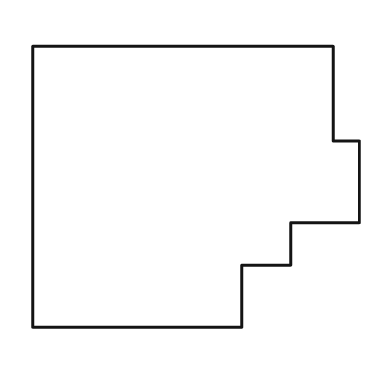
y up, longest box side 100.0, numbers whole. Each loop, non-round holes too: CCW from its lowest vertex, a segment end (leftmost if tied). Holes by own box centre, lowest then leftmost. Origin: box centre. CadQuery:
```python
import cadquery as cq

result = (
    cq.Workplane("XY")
    .moveTo(-50.0, -43.0)
    .lineTo(14.0, -43.0)
    .lineTo(14.0, -24.0)
    .lineTo(29.0, -24.0)
    .lineTo(29.0, -11.0)
    .lineTo(50.0, -11.0)
    .lineTo(50.0, 14.0)
    .lineTo(42.0, 14.0)
    .lineTo(42.0, 43.0)
    .lineTo(-50.0, 43.0)
    .close()
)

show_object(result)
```